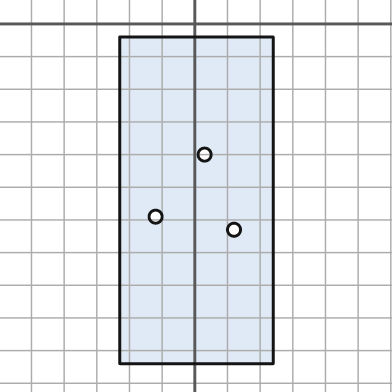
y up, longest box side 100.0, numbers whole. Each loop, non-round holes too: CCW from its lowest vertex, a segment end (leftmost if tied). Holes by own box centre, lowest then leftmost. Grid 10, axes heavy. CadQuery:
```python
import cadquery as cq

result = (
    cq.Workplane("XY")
    .moveTo(-23.0, -104.0)
    .lineTo(24.0, -104.0)
    .lineTo(24.0, -4.0)
    .lineTo(-23.0, -4.0)
    .close()
    .moveTo(12.0, -63.0)
    .circle(2.0)
    .moveTo(-12.0, -59.0)
    .circle(2.0)
    .moveTo(3.0, -40.0)
    .circle(2.0)
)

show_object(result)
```